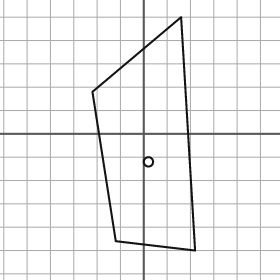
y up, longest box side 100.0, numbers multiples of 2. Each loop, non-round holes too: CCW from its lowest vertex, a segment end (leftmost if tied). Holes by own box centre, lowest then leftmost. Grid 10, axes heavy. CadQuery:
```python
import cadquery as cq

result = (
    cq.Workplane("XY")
    .moveTo(22.0, -50.0)
    .lineTo(16.0, 50.0)
    .lineTo(-22.0, 18.0)
    .lineTo(-12.0, -46.0)
    .close()
    .moveTo(2.0, -12.0)
    .circle(2.0)
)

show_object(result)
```